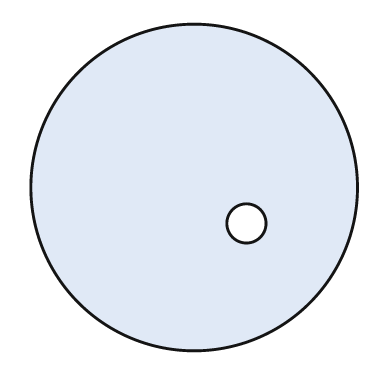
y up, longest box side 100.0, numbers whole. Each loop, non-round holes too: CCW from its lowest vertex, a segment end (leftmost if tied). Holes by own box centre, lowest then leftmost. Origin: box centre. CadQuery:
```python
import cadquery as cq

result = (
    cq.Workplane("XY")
    .moveTo(0.0, 0.0)
    .circle(50.0)
    .moveTo(16.0, -11.0)
    .circle(6.0)
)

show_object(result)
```